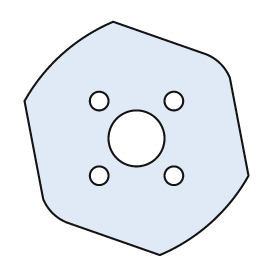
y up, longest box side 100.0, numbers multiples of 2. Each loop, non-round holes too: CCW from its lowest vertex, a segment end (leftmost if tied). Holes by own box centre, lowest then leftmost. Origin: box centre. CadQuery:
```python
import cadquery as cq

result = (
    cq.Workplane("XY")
    .moveTo(10.0, -50.0)
    .threePointArc((32.0, -36.0), (48.0, -16.0))
    .lineTo(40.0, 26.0)
    .threePointArc((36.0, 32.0), (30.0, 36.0))
    .lineTo(-10.0, 50.0)
    .threePointArc((-32.0, 36.0), (-48.0, 16.0))
    .lineTo(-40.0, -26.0)
    .threePointArc((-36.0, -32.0), (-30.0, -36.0))
    .close()
    .moveTo(-16.0, -16.0)
    .circle(4.0)
    .moveTo(16.0, -16.0)
    .circle(4.0)
    .moveTo(0.0, 0.0)
    .circle(12.0)
    .moveTo(-16.0, 16.0)
    .circle(4.0)
    .moveTo(16.0, 16.0)
    .circle(4.0)
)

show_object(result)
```